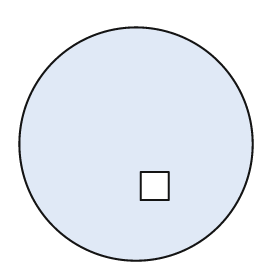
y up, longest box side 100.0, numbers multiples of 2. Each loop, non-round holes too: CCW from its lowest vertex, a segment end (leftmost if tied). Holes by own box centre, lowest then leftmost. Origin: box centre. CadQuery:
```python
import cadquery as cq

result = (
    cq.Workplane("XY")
    .moveTo(0.0, 0.0)
    .circle(50.0)
    .moveTo(2.0, -24.0)
    .lineTo(14.0, -24.0)
    .lineTo(14.0, -12.0)
    .lineTo(2.0, -12.0)
    .close()
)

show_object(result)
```